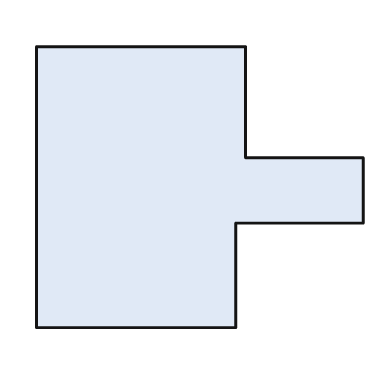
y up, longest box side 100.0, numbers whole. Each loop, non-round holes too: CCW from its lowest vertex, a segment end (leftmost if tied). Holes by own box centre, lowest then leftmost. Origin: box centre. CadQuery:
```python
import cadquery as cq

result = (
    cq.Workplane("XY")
    .moveTo(-50.0, -43.0)
    .lineTo(11.0, -43.0)
    .lineTo(11.0, -11.0)
    .lineTo(50.0, -11.0)
    .lineTo(50.0, 9.0)
    .lineTo(14.0, 9.0)
    .lineTo(14.0, 43.0)
    .lineTo(-50.0, 43.0)
    .close()
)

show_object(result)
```